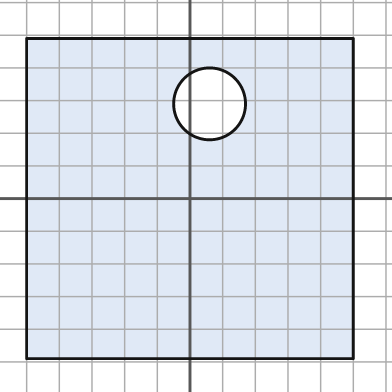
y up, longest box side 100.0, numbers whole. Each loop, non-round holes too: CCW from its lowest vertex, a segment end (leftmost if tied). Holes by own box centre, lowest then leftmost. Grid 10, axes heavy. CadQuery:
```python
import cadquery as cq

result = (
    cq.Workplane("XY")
    .moveTo(-50.0, -49.0)
    .lineTo(50.0, -49.0)
    .lineTo(50.0, 49.0)
    .lineTo(-50.0, 49.0)
    .close()
    .moveTo(6.0, 29.0)
    .circle(11.0)
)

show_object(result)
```